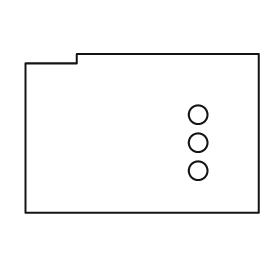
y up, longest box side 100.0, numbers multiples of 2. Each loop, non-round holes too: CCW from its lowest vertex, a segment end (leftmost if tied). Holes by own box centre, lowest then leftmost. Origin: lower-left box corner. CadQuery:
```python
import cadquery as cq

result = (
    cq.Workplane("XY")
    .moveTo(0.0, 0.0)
    .lineTo(100.0, 0.0)
    .lineTo(100.0, 68.0)
    .lineTo(22.0, 68.0)
    .lineTo(22.0, 64.0)
    .lineTo(0.0, 64.0)
    .close()
    .moveTo(74.0, 18.0)
    .circle(4.0)
    .moveTo(74.0, 30.0)
    .circle(4.0)
    .moveTo(74.0, 42.0)
    .circle(4.0)
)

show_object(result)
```